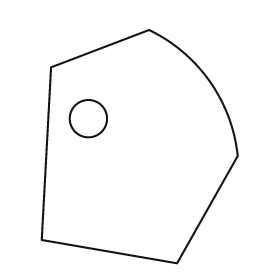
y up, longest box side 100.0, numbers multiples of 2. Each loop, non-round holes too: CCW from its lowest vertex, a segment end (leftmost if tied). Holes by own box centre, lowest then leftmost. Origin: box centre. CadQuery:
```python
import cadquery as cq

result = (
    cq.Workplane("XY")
    .moveTo(16.0, -50.0)
    .lineTo(42.0, -4.0)
    .threePointArc((30.0, 28.0), (4.0, 50.0))
    .lineTo(-38.0, 34.0)
    .lineTo(-42.0, -40.0)
    .close()
    .moveTo(-22.0, 12.0)
    .circle(8.0)
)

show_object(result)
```